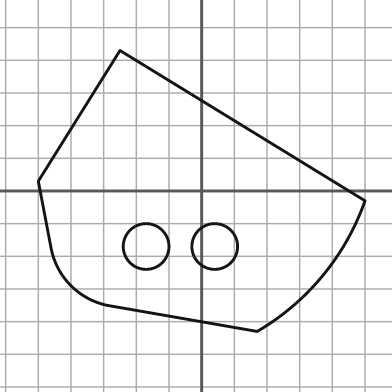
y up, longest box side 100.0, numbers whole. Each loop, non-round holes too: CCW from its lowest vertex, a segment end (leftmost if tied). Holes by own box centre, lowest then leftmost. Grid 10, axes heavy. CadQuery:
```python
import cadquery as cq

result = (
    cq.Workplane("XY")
    .moveTo(17.0, -43.0)
    .threePointArc((37.0, -26.0), (50.0, -3.0))
    .lineTo(-25.0, 43.0)
    .lineTo(-50.0, 3.0)
    .lineTo(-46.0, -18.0)
    .threePointArc((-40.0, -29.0), (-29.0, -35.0))
    .close()
    .moveTo(-17.0, -17.0)
    .circle(7.0)
    .moveTo(4.0, -17.0)
    .circle(7.0)
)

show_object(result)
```